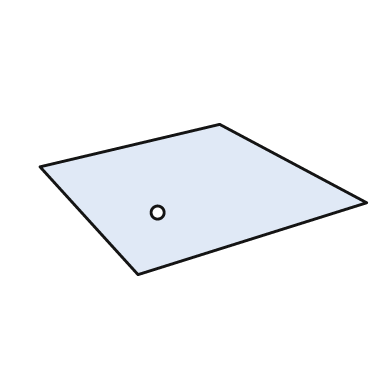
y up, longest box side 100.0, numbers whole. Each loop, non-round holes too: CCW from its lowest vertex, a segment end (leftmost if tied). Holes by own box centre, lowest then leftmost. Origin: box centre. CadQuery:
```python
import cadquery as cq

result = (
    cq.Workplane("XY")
    .moveTo(-20.0, -23.0)
    .lineTo(50.0, -1.0)
    .lineTo(5.0, 23.0)
    .lineTo(-50.0, 10.0)
    .close()
    .moveTo(-14.0, -4.0)
    .circle(2.0)
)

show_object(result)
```